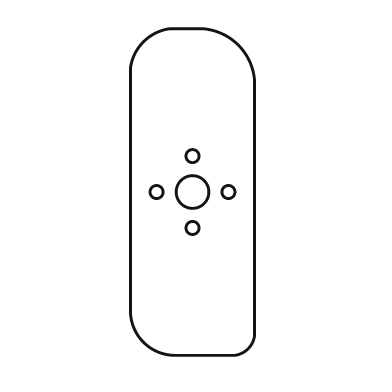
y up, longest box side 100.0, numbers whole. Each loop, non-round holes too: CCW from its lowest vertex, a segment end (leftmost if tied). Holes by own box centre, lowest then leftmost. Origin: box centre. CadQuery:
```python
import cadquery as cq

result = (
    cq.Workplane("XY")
    .moveTo(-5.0, -50.0)
    .lineTo(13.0, -50.0)
    .threePointArc((17.0, -48.0), (19.0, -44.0))
    .lineTo(19.0, 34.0)
    .threePointArc((14.0, 45.0), (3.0, 50.0))
    .lineTo(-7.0, 50.0)
    .threePointArc((-15.0, 46.0), (-19.0, 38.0))
    .lineTo(-19.0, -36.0)
    .threePointArc((-15.0, -46.0), (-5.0, -50.0))
    .close()
    .moveTo(0.0, -11.0)
    .circle(2.0)
    .moveTo(-11.0, 0.0)
    .circle(2.0)
    .moveTo(0.0, 0.0)
    .circle(5.0)
    .moveTo(11.0, 0.0)
    .circle(2.0)
    .moveTo(0.0, 11.0)
    .circle(2.0)
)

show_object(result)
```